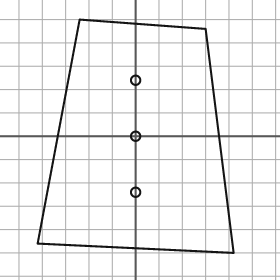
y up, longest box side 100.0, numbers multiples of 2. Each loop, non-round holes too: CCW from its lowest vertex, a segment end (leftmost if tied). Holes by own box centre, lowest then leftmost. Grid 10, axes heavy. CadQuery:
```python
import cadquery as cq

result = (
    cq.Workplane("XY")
    .moveTo(42.0, -50.0)
    .lineTo(30.0, 46.0)
    .lineTo(-24.0, 50.0)
    .lineTo(-42.0, -46.0)
    .close()
    .moveTo(0.0, -24.0)
    .circle(2.0)
    .moveTo(0.0, 0.0)
    .circle(2.0)
    .moveTo(0.0, 24.0)
    .circle(2.0)
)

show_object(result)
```